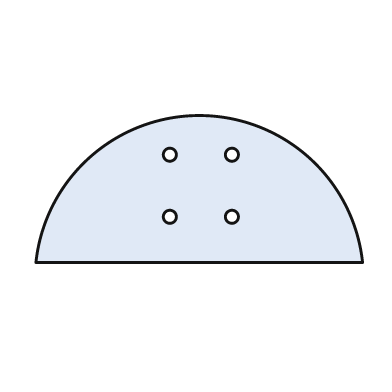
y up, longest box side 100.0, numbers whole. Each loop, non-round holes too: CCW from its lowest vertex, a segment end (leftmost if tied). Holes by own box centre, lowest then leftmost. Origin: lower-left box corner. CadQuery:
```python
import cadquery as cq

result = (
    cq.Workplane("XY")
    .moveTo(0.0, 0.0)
    .lineTo(100.0, 0.0)
    .threePointArc((50.0, 45.0), (0.0, 0.0))
    .close()
    .moveTo(41.0, 14.0)
    .circle(2.0)
    .moveTo(60.0, 14.0)
    .circle(2.0)
    .moveTo(41.0, 33.0)
    .circle(2.0)
    .moveTo(60.0, 33.0)
    .circle(2.0)
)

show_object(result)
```